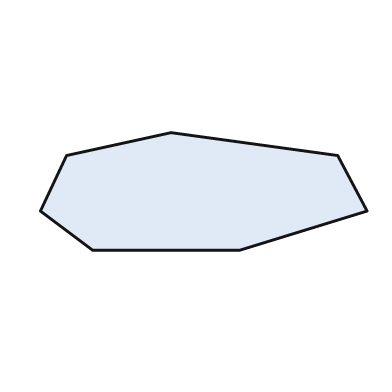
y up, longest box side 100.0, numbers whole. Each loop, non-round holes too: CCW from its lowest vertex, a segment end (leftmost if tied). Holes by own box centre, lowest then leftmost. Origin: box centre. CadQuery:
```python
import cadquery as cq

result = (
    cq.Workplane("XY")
    .moveTo(-34.0, -18.0)
    .lineTo(11.0, -18.0)
    .lineTo(50.0, -6.0)
    .lineTo(41.0, 11.0)
    .lineTo(-10.0, 18.0)
    .lineTo(-42.0, 11.0)
    .lineTo(-50.0, -6.0)
    .close()
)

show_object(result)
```